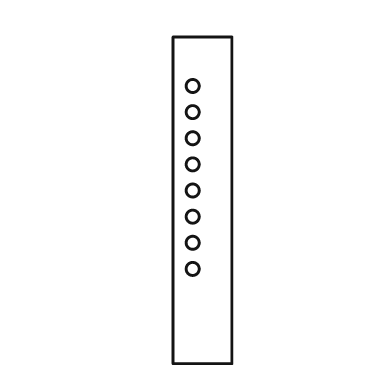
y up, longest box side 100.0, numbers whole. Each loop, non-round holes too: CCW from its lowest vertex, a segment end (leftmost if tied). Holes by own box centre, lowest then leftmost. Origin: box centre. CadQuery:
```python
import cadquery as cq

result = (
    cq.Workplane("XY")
    .moveTo(-9.0, -50.0)
    .lineTo(9.0, -50.0)
    .lineTo(9.0, 50.0)
    .lineTo(-9.0, 50.0)
    .close()
    .moveTo(-3.0, -21.0)
    .circle(2.0)
    .moveTo(-3.0, -13.0)
    .circle(2.0)
    .moveTo(-3.0, -5.0)
    .circle(2.0)
    .moveTo(-3.0, 3.0)
    .circle(2.0)
    .moveTo(-3.0, 11.0)
    .circle(2.0)
    .moveTo(-3.0, 19.0)
    .circle(2.0)
    .moveTo(-3.0, 27.0)
    .circle(2.0)
    .moveTo(-3.0, 35.0)
    .circle(2.0)
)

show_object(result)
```